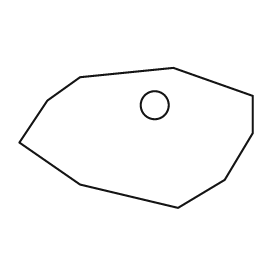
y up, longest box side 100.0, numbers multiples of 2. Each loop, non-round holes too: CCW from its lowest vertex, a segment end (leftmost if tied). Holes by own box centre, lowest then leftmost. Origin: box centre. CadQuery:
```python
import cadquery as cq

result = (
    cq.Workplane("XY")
    .moveTo(18.0, -30.0)
    .lineTo(38.0, -18.0)
    .lineTo(50.0, 2.0)
    .lineTo(50.0, 18.0)
    .lineTo(16.0, 30.0)
    .lineTo(-24.0, 26.0)
    .lineTo(-38.0, 16.0)
    .lineTo(-50.0, -2.0)
    .lineTo(-24.0, -20.0)
    .close()
    .moveTo(8.0, 14.0)
    .circle(6.0)
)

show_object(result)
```